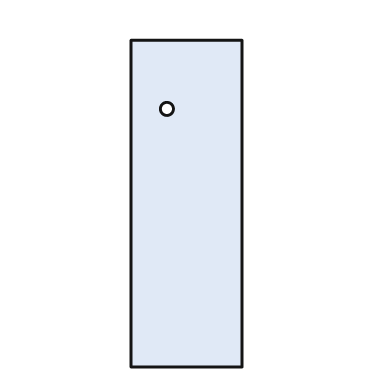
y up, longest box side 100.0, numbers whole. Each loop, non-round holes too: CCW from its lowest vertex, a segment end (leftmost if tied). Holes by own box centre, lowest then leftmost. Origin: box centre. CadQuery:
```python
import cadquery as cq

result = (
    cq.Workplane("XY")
    .moveTo(-17.0, -50.0)
    .lineTo(17.0, -50.0)
    .lineTo(17.0, 50.0)
    .lineTo(-17.0, 50.0)
    .close()
    .moveTo(-6.0, 29.0)
    .circle(2.0)
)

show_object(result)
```